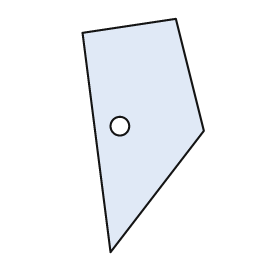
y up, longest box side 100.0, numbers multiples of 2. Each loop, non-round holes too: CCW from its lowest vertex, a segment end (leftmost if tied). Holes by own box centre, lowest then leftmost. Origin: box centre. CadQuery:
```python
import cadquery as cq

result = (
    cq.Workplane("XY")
    .moveTo(-14.0, -50.0)
    .lineTo(26.0, 2.0)
    .lineTo(14.0, 50.0)
    .lineTo(-26.0, 44.0)
    .close()
    .moveTo(-10.0, 4.0)
    .circle(4.0)
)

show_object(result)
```